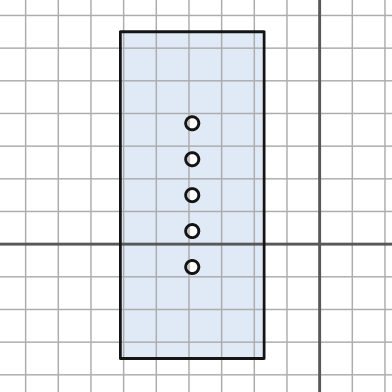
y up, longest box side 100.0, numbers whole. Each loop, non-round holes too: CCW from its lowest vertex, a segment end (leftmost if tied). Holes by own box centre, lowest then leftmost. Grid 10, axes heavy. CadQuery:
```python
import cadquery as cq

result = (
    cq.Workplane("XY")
    .moveTo(-61.0, -35.0)
    .lineTo(-17.0, -35.0)
    .lineTo(-17.0, 65.0)
    .lineTo(-61.0, 65.0)
    .close()
    .moveTo(-39.0, -7.0)
    .circle(2.0)
    .moveTo(-39.0, 4.0)
    .circle(2.0)
    .moveTo(-39.0, 15.0)
    .circle(2.0)
    .moveTo(-39.0, 26.0)
    .circle(2.0)
    .moveTo(-39.0, 37.0)
    .circle(2.0)
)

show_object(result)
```